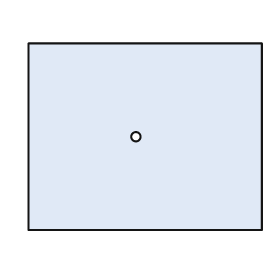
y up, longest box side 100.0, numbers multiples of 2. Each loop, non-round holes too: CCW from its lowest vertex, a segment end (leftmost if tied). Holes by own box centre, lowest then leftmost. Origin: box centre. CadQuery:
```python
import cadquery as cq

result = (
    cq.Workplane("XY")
    .moveTo(-50.0, -40.0)
    .lineTo(50.0, -40.0)
    .lineTo(50.0, 40.0)
    .lineTo(-50.0, 40.0)
    .close()
    .moveTo(-4.0, 0.0)
    .circle(2.0)
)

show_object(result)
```